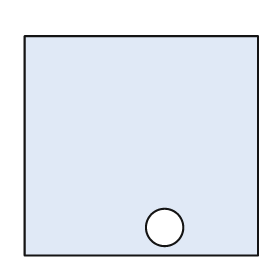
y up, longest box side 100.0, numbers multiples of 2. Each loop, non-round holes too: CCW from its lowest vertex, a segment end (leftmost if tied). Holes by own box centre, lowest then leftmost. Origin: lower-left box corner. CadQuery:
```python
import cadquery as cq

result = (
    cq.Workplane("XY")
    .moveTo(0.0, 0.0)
    .lineTo(100.0, 0.0)
    .lineTo(100.0, 94.0)
    .lineTo(0.0, 94.0)
    .close()
    .moveTo(60.0, 12.0)
    .circle(8.0)
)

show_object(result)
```